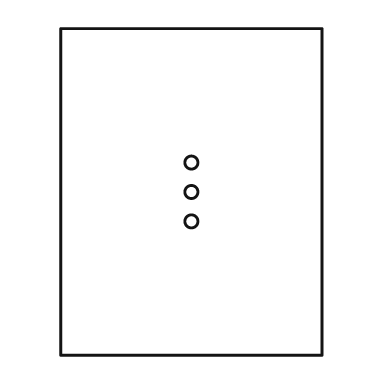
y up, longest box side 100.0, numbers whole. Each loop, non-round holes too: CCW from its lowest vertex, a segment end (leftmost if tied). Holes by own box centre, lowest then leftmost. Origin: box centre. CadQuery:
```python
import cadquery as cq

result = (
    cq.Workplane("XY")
    .moveTo(-40.0, -50.0)
    .lineTo(40.0, -50.0)
    .lineTo(40.0, 50.0)
    .lineTo(-40.0, 50.0)
    .close()
    .moveTo(0.0, -9.0)
    .circle(2.0)
    .moveTo(0.0, 0.0)
    .circle(2.0)
    .moveTo(0.0, 9.0)
    .circle(2.0)
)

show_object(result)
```